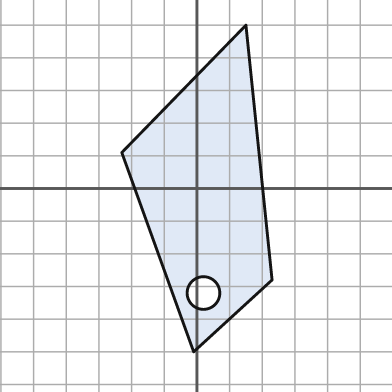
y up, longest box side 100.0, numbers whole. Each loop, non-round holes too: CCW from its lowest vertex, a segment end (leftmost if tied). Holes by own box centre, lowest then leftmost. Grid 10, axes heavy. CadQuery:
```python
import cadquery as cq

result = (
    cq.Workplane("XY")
    .moveTo(-1.0, -50.0)
    .lineTo(23.0, -28.0)
    .lineTo(15.0, 50.0)
    .lineTo(-23.0, 11.0)
    .close()
    .moveTo(2.0, -32.0)
    .circle(5.0)
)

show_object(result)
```